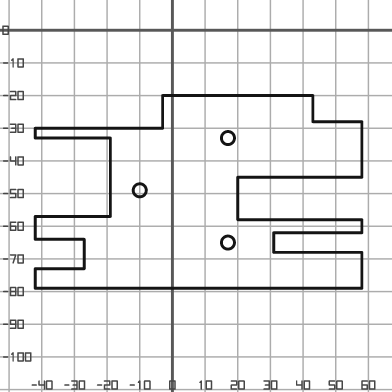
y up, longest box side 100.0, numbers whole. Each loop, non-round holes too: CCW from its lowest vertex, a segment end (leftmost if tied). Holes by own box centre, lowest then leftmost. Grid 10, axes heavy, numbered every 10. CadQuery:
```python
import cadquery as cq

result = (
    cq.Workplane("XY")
    .moveTo(-42.0, -79.0)
    .lineTo(58.0, -79.0)
    .lineTo(58.0, -68.0)
    .lineTo(31.0, -68.0)
    .lineTo(31.0, -62.0)
    .lineTo(58.0, -62.0)
    .lineTo(58.0, -58.0)
    .lineTo(20.0, -58.0)
    .lineTo(20.0, -45.0)
    .lineTo(58.0, -45.0)
    .lineTo(58.0, -28.0)
    .lineTo(43.0, -28.0)
    .lineTo(43.0, -20.0)
    .lineTo(-3.0, -20.0)
    .lineTo(-3.0, -30.0)
    .lineTo(-42.0, -30.0)
    .lineTo(-42.0, -33.0)
    .lineTo(-19.0, -33.0)
    .lineTo(-19.0, -57.0)
    .lineTo(-42.0, -57.0)
    .lineTo(-42.0, -64.0)
    .lineTo(-27.0, -64.0)
    .lineTo(-27.0, -73.0)
    .lineTo(-42.0, -73.0)
    .close()
    .moveTo(17.0, -65.0)
    .circle(2.0)
    .moveTo(-10.0, -49.0)
    .circle(2.0)
    .moveTo(17.0, -33.0)
    .circle(2.0)
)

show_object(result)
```